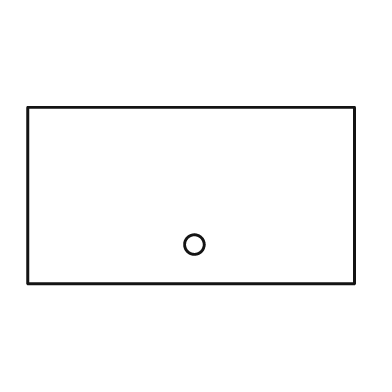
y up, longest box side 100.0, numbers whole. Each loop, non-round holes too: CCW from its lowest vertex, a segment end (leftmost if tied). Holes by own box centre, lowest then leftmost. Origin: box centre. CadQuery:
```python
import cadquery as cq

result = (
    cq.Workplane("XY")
    .moveTo(-50.0, -27.0)
    .lineTo(50.0, -27.0)
    .lineTo(50.0, 27.0)
    .lineTo(-50.0, 27.0)
    .close()
    .moveTo(1.0, -15.0)
    .circle(3.0)
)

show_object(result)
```